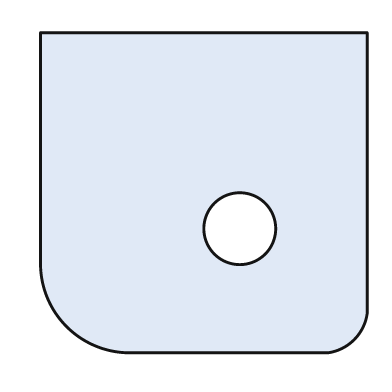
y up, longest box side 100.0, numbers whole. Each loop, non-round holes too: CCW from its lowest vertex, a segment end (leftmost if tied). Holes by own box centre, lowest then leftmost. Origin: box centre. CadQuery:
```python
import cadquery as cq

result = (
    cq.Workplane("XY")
    .moveTo(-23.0, -49.0)
    .lineTo(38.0, -49.0)
    .threePointArc((46.0, -45.0), (50.0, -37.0))
    .lineTo(50.0, 49.0)
    .lineTo(-50.0, 49.0)
    .lineTo(-50.0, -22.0)
    .threePointArc((-42.0, -41.0), (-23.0, -49.0))
    .close()
    .moveTo(11.0, -11.0)
    .circle(11.0)
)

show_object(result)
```